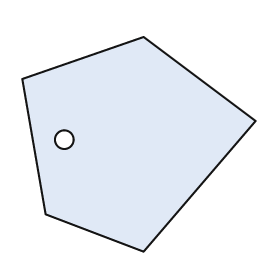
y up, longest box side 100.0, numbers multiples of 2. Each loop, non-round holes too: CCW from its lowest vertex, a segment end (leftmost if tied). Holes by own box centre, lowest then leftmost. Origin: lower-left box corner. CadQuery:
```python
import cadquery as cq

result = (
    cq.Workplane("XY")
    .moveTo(52.0, 0.0)
    .lineTo(100.0, 56.0)
    .lineTo(52.0, 92.0)
    .lineTo(0.0, 74.0)
    .lineTo(10.0, 16.0)
    .close()
    .moveTo(18.0, 48.0)
    .circle(4.0)
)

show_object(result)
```